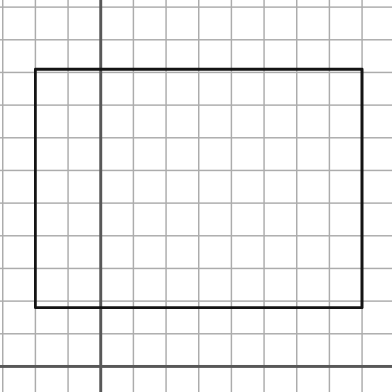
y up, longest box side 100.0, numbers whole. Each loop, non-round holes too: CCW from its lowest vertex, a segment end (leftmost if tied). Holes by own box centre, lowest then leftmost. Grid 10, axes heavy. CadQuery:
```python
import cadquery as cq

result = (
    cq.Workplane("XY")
    .moveTo(-20.0, 18.0)
    .lineTo(80.0, 18.0)
    .lineTo(80.0, 91.0)
    .lineTo(-20.0, 91.0)
    .close()
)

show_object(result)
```